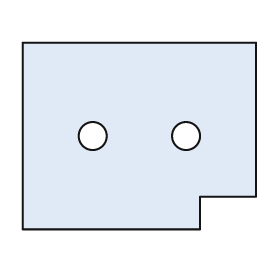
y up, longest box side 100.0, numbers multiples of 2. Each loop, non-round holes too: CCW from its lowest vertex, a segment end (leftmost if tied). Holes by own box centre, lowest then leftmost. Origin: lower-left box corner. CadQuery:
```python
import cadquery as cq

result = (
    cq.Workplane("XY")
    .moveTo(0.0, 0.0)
    .lineTo(76.0, 0.0)
    .lineTo(76.0, 14.0)
    .lineTo(100.0, 14.0)
    .lineTo(100.0, 80.0)
    .lineTo(0.0, 80.0)
    .close()
    .moveTo(30.0, 40.0)
    .circle(6.0)
    .moveTo(70.0, 40.0)
    .circle(6.0)
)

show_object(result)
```